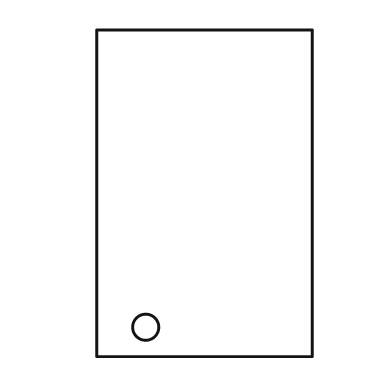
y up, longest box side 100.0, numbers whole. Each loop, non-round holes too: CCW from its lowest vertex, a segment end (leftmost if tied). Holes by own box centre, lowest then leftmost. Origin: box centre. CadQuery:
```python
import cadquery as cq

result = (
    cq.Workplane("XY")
    .moveTo(-33.0, -50.0)
    .lineTo(33.0, -50.0)
    .lineTo(33.0, 50.0)
    .lineTo(-33.0, 50.0)
    .close()
    .moveTo(-18.0, -41.0)
    .circle(4.0)
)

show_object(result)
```